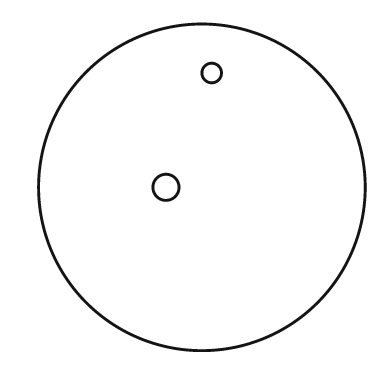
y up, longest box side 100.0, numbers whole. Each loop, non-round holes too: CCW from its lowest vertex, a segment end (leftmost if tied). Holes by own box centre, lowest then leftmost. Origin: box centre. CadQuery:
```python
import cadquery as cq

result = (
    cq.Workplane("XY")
    .moveTo(0.0, 0.0)
    .circle(50.0)
    .moveTo(-11.0, 0.0)
    .circle(4.0)
    .moveTo(3.0, 35.0)
    .circle(3.0)
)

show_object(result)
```